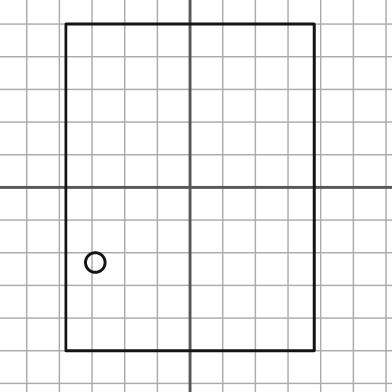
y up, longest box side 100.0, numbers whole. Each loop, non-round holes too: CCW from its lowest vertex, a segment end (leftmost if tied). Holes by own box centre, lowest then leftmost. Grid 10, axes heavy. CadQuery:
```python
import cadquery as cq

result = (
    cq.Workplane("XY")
    .moveTo(-38.0, -50.0)
    .lineTo(38.0, -50.0)
    .lineTo(38.0, 50.0)
    .lineTo(-38.0, 50.0)
    .close()
    .moveTo(-29.0, -23.0)
    .circle(3.0)
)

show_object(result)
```